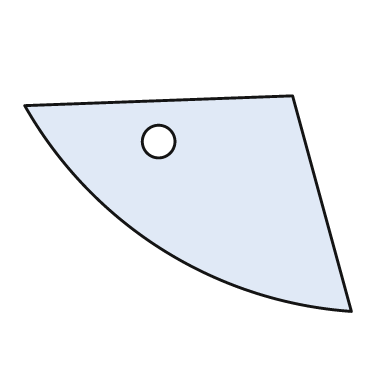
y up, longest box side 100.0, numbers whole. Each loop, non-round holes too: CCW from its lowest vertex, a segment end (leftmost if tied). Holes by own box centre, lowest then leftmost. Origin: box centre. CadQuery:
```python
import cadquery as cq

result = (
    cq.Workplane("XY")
    .moveTo(50.0, -33.0)
    .lineTo(32.0, 33.0)
    .lineTo(-50.0, 30.0)
    .threePointArc((-8.0, -14.0), (50.0, -33.0))
    .close()
    .moveTo(-9.0, 19.0)
    .circle(5.0)
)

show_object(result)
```